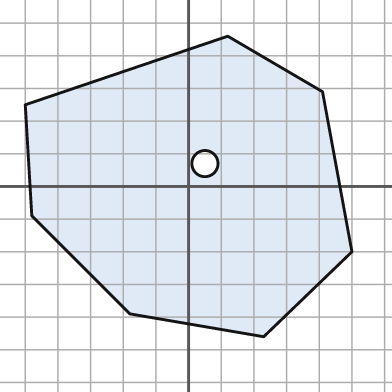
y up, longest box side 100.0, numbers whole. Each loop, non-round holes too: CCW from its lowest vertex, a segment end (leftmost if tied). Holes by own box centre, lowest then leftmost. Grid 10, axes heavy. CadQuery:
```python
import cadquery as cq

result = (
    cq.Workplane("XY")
    .moveTo(23.0, -46.0)
    .lineTo(50.0, -20.0)
    .lineTo(41.0, 29.0)
    .lineTo(12.0, 46.0)
    .lineTo(-50.0, 25.0)
    .lineTo(-48.0, -9.0)
    .lineTo(-18.0, -39.0)
    .close()
    .moveTo(5.0, 7.0)
    .circle(4.0)
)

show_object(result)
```